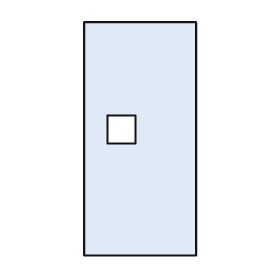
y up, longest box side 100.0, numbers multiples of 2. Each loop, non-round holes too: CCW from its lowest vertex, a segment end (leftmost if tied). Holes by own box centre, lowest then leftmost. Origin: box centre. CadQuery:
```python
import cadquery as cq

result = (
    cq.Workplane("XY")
    .moveTo(-24.0, -50.0)
    .lineTo(24.0, -50.0)
    .lineTo(24.0, 50.0)
    .lineTo(-24.0, 50.0)
    .close()
    .moveTo(-14.0, -2.0)
    .lineTo(-2.0, -2.0)
    .lineTo(-2.0, 10.0)
    .lineTo(-14.0, 10.0)
    .close()
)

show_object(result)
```